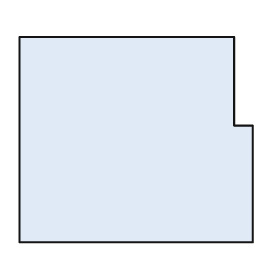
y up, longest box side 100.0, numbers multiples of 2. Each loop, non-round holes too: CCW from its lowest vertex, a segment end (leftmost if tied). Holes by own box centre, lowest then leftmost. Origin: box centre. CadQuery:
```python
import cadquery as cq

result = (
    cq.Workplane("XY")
    .moveTo(-50.0, -44.0)
    .lineTo(50.0, -44.0)
    .lineTo(50.0, 6.0)
    .lineTo(42.0, 6.0)
    .lineTo(42.0, 44.0)
    .lineTo(-50.0, 44.0)
    .close()
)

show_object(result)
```